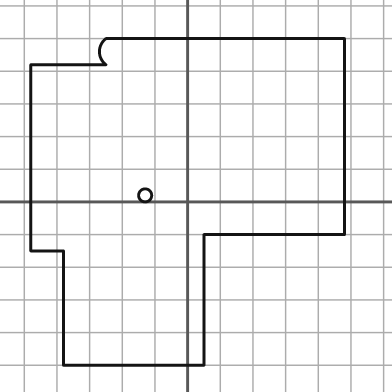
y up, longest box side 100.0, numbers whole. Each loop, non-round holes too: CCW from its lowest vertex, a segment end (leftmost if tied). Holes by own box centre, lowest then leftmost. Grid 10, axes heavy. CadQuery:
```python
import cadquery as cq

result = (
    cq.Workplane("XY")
    .moveTo(-38.0, -50.0)
    .lineTo(5.0, -50.0)
    .lineTo(5.0, -10.0)
    .lineTo(48.0, -10.0)
    .lineTo(48.0, 50.0)
    .lineTo(-25.0, 50.0)
    .threePointArc((-27.0, 46.0), (-25.0, 42.0))
    .lineTo(-48.0, 42.0)
    .lineTo(-48.0, -15.0)
    .lineTo(-38.0, -15.0)
    .close()
    .moveTo(-13.0, 2.0)
    .circle(2.0)
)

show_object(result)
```